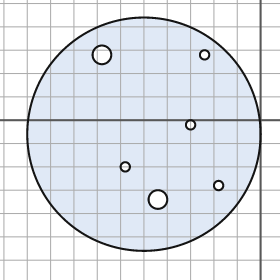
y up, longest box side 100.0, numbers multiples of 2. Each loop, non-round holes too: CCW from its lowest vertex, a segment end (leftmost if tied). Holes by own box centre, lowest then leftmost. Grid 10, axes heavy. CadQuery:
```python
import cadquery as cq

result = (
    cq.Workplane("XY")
    .moveTo(-50.0, -6.0)
    .circle(50.0)
    .moveTo(-44.0, -34.0)
    .circle(4.0)
    .moveTo(-18.0, -28.0)
    .circle(2.0)
    .moveTo(-58.0, -20.0)
    .circle(2.0)
    .moveTo(-30.0, -2.0)
    .circle(2.0)
    .moveTo(-68.0, 28.0)
    .circle(4.0)
    .moveTo(-24.0, 28.0)
    .circle(2.0)
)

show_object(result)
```